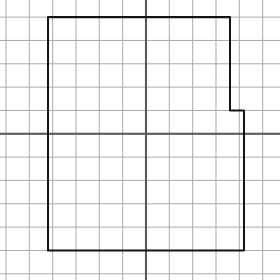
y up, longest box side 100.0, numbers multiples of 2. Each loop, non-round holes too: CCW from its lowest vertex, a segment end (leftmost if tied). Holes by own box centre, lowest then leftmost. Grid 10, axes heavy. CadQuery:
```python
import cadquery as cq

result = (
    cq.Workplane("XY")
    .moveTo(-42.0, -50.0)
    .lineTo(42.0, -50.0)
    .lineTo(42.0, 10.0)
    .lineTo(36.0, 10.0)
    .lineTo(36.0, 50.0)
    .lineTo(-42.0, 50.0)
    .close()
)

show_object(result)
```